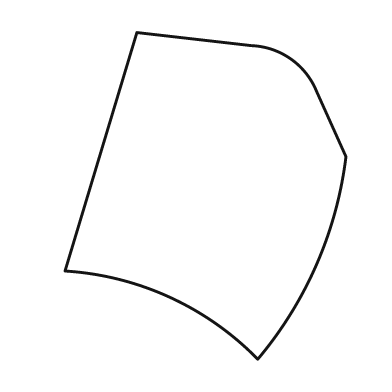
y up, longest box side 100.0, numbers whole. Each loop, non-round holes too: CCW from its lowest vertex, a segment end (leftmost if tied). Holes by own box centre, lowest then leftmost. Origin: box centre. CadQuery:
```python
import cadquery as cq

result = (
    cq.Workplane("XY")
    .moveTo(16.0, -50.0)
    .threePointArc((34.0, -21.0), (43.0, 12.0))
    .lineTo(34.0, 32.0)
    .threePointArc((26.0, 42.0), (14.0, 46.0))
    .lineTo(-21.0, 50.0)
    .lineTo(-43.0, -23.0)
    .threePointArc((-11.0, -31.0), (16.0, -50.0))
    .close()
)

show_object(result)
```